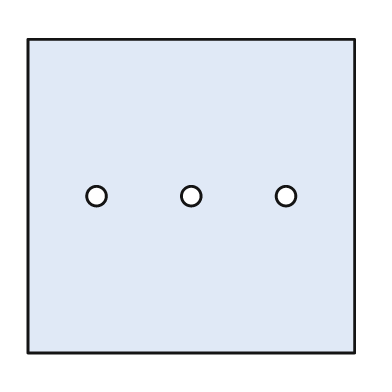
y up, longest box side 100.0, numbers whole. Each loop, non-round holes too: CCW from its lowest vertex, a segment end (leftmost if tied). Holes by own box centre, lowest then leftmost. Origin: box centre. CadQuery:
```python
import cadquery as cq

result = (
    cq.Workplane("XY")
    .moveTo(-50.0, -48.0)
    .lineTo(50.0, -48.0)
    .lineTo(50.0, 48.0)
    .lineTo(-50.0, 48.0)
    .close()
    .moveTo(-29.0, 0.0)
    .circle(3.0)
    .moveTo(0.0, 0.0)
    .circle(3.0)
    .moveTo(29.0, 0.0)
    .circle(3.0)
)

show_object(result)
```